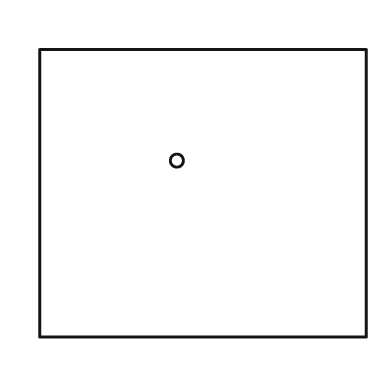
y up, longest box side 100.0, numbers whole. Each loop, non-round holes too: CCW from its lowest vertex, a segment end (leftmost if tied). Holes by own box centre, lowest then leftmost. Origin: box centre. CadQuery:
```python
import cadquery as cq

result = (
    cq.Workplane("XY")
    .moveTo(-50.0, -44.0)
    .lineTo(50.0, -44.0)
    .lineTo(50.0, 44.0)
    .lineTo(-50.0, 44.0)
    .close()
    .moveTo(-8.0, 10.0)
    .circle(2.0)
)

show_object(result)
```